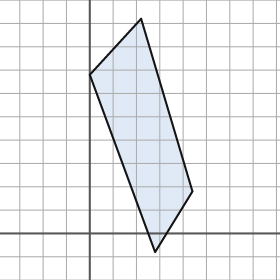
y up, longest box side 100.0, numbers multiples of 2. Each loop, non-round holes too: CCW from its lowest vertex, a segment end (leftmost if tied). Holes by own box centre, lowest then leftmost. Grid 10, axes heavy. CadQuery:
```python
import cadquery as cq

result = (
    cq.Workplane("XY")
    .moveTo(28.0, -8.0)
    .lineTo(44.0, 18.0)
    .lineTo(22.0, 92.0)
    .lineTo(0.0, 68.0)
    .close()
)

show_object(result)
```